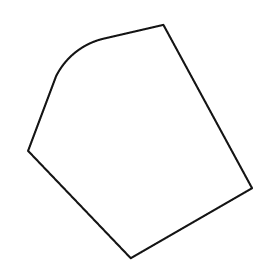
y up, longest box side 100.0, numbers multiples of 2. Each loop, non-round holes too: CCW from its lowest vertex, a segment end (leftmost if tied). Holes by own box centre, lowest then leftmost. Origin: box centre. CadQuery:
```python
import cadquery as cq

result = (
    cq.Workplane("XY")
    .moveTo(-4.0, -50.0)
    .lineTo(48.0, -20.0)
    .lineTo(10.0, 50.0)
    .lineTo(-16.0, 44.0)
    .threePointArc((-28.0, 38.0), (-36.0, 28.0))
    .lineTo(-48.0, -4.0)
    .close()
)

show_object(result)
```